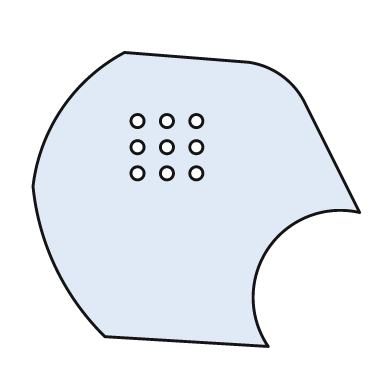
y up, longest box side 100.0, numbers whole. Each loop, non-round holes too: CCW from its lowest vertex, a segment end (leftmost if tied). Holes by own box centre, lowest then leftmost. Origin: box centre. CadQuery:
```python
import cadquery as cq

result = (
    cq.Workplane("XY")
    .moveTo(22.0, -45.0)
    .threePointArc((22.0, -15.0), (50.0, -4.0))
    .lineTo(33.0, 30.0)
    .threePointArc((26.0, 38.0), (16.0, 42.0))
    .lineTo(-22.0, 45.0)
    .threePointArc((-41.0, 28.0), (-50.0, 4.0))
    .threePointArc((-43.0, -21.0), (-28.0, -42.0))
    .close()
    .moveTo(-18.0, 8.0)
    .circle(2.0)
    .moveTo(-9.0, 8.0)
    .circle(2.0)
    .moveTo(0.0, 8.0)
    .circle(2.0)
    .moveTo(-18.0, 16.0)
    .circle(2.0)
    .moveTo(-9.0, 16.0)
    .circle(2.0)
    .moveTo(0.0, 16.0)
    .circle(2.0)
    .moveTo(-18.0, 24.0)
    .circle(2.0)
    .moveTo(-9.0, 24.0)
    .circle(2.0)
    .moveTo(0.0, 24.0)
    .circle(2.0)
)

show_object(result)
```